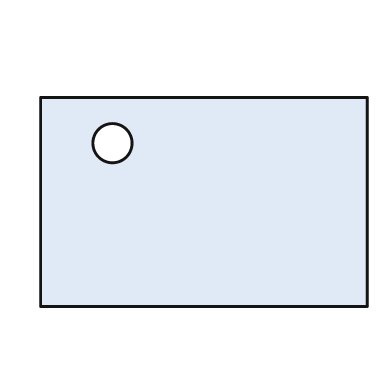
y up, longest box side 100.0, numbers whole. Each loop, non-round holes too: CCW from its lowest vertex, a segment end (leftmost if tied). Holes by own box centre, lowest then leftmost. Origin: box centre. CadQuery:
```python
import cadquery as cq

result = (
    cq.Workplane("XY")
    .moveTo(-50.0, -32.0)
    .lineTo(50.0, -32.0)
    .lineTo(50.0, 32.0)
    .lineTo(-50.0, 32.0)
    .close()
    .moveTo(-28.0, 18.0)
    .circle(6.0)
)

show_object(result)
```